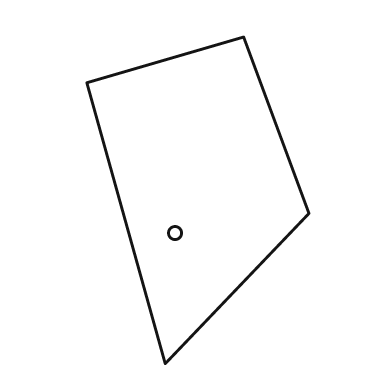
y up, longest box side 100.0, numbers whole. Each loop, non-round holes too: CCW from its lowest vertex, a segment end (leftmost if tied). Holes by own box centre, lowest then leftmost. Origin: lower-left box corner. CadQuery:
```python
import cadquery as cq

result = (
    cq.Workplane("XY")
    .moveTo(24.0, 0.0)
    .lineTo(68.0, 46.0)
    .lineTo(48.0, 100.0)
    .lineTo(0.0, 86.0)
    .close()
    .moveTo(27.0, 40.0)
    .circle(2.0)
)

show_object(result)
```